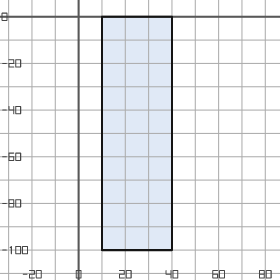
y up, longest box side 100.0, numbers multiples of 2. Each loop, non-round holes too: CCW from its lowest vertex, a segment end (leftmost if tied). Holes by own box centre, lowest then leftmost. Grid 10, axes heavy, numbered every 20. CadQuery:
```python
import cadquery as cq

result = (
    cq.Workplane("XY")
    .moveTo(10.0, -100.0)
    .lineTo(40.0, -100.0)
    .lineTo(40.0, 0.0)
    .lineTo(10.0, 0.0)
    .close()
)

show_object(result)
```